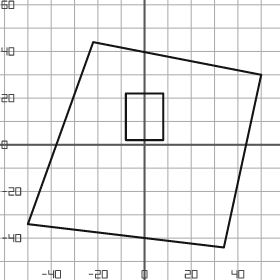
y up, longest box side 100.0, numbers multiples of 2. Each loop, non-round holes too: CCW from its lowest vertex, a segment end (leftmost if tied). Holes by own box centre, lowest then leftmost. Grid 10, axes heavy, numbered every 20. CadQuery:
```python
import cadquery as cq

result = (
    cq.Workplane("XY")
    .moveTo(34.0, -44.0)
    .lineTo(50.0, 30.0)
    .lineTo(-22.0, 44.0)
    .lineTo(-50.0, -34.0)
    .close()
    .moveTo(-8.0, 2.0)
    .lineTo(8.0, 2.0)
    .lineTo(8.0, 22.0)
    .lineTo(-8.0, 22.0)
    .close()
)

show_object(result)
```